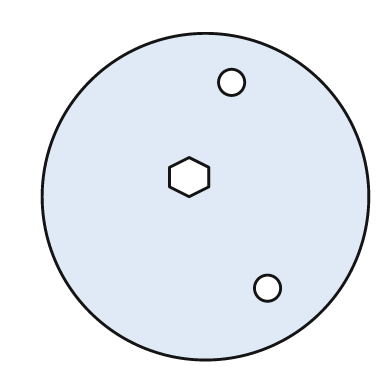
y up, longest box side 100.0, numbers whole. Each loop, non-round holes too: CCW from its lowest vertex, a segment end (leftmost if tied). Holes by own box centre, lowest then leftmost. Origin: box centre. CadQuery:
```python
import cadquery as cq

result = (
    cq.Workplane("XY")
    .moveTo(0.0, 0.0)
    .circle(50.0)
    .moveTo(19.0, -28.0)
    .circle(4.0)
    .moveTo(-5.0, 0.0)
    .lineTo(1.0, 3.0)
    .lineTo(1.0, 9.0)
    .lineTo(-5.0, 12.0)
    .lineTo(-11.0, 9.0)
    .lineTo(-11.0, 3.0)
    .close()
    .moveTo(8.0, 35.0)
    .circle(4.0)
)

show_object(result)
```